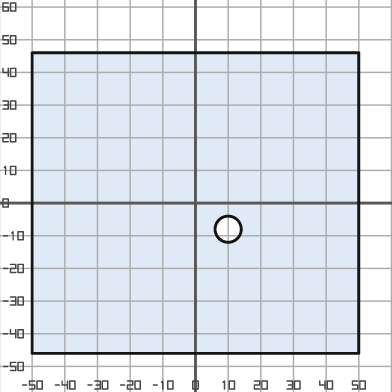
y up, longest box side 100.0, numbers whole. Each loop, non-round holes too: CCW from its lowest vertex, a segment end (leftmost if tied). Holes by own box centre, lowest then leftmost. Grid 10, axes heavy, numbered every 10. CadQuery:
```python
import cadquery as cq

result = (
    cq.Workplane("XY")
    .moveTo(-50.0, -46.0)
    .lineTo(50.0, -46.0)
    .lineTo(50.0, 46.0)
    .lineTo(-50.0, 46.0)
    .close()
    .moveTo(10.0, -8.0)
    .circle(4.0)
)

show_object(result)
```